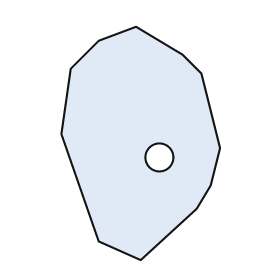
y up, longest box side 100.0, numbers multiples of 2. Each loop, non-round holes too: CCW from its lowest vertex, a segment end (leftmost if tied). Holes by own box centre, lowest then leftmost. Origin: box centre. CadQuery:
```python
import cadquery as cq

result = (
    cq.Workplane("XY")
    .moveTo(0.0, -50.0)
    .lineTo(24.0, -28.0)
    .lineTo(30.0, -18.0)
    .lineTo(34.0, -2.0)
    .lineTo(26.0, 30.0)
    .lineTo(18.0, 38.0)
    .lineTo(-2.0, 50.0)
    .lineTo(-18.0, 44.0)
    .lineTo(-30.0, 32.0)
    .lineTo(-34.0, 4.0)
    .lineTo(-18.0, -42.0)
    .close()
    .moveTo(8.0, -6.0)
    .circle(6.0)
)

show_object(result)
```